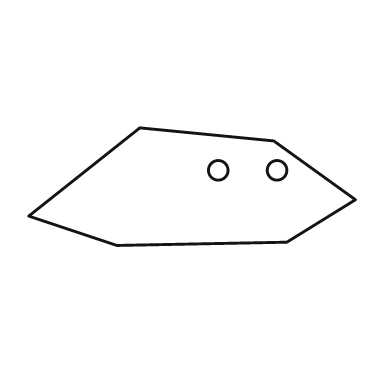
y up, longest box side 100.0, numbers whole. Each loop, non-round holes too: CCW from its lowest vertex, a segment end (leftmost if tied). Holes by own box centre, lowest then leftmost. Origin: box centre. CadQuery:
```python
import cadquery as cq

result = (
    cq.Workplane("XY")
    .moveTo(-23.0, -18.0)
    .lineTo(29.0, -17.0)
    .lineTo(50.0, -4.0)
    .lineTo(25.0, 14.0)
    .lineTo(-16.0, 18.0)
    .lineTo(-50.0, -9.0)
    .close()
    .moveTo(8.0, 5.0)
    .circle(3.0)
    .moveTo(26.0, 5.0)
    .circle(3.0)
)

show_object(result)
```